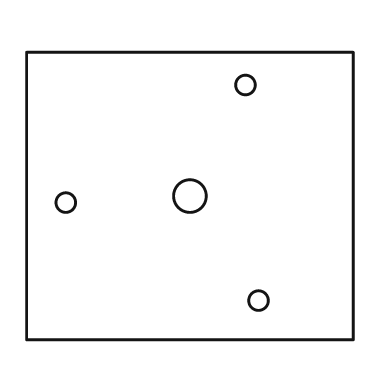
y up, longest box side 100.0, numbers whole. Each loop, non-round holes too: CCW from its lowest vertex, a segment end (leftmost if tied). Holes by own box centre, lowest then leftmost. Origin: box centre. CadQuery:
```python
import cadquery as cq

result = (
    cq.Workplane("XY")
    .moveTo(-50.0, -44.0)
    .lineTo(50.0, -44.0)
    .lineTo(50.0, 44.0)
    .lineTo(-50.0, 44.0)
    .close()
    .moveTo(21.0, -32.0)
    .circle(3.0)
    .moveTo(-38.0, -2.0)
    .circle(3.0)
    .moveTo(0.0, 0.0)
    .circle(5.0)
    .moveTo(17.0, 34.0)
    .circle(3.0)
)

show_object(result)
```